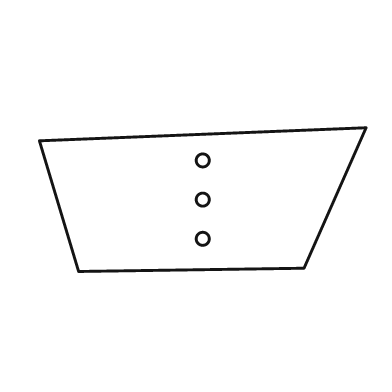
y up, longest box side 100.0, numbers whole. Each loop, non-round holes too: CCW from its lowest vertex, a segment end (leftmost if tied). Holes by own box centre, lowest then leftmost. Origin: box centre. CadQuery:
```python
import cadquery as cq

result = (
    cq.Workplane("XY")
    .moveTo(-38.0, -22.0)
    .lineTo(31.0, -21.0)
    .lineTo(50.0, 22.0)
    .lineTo(-50.0, 18.0)
    .close()
    .moveTo(0.0, -12.0)
    .circle(2.0)
    .moveTo(0.0, 0.0)
    .circle(2.0)
    .moveTo(0.0, 12.0)
    .circle(2.0)
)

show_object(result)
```